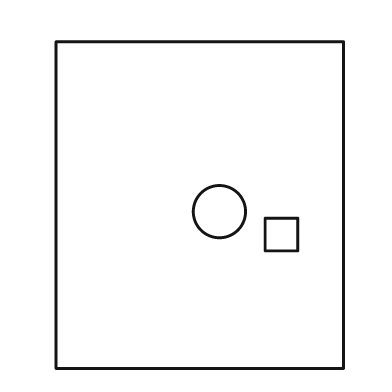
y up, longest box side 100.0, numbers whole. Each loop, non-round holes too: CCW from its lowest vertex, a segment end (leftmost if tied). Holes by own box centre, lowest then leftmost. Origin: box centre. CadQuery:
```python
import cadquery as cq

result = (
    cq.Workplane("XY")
    .moveTo(-44.0, -50.0)
    .lineTo(44.0, -50.0)
    .lineTo(44.0, 50.0)
    .lineTo(-44.0, 50.0)
    .close()
    .moveTo(20.0, -14.0)
    .lineTo(30.0, -14.0)
    .lineTo(30.0, -4.0)
    .lineTo(20.0, -4.0)
    .close()
    .moveTo(6.0, -2.0)
    .circle(8.0)
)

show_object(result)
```